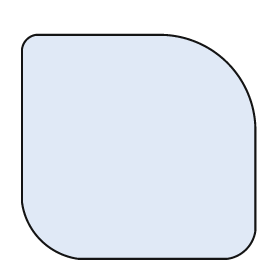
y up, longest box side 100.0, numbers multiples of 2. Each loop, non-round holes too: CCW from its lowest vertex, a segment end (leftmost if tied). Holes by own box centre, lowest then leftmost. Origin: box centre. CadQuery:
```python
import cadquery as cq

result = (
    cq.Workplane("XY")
    .moveTo(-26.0, -48.0)
    .lineTo(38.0, -48.0)
    .threePointArc((46.0, -44.0), (50.0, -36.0))
    .lineTo(50.0, 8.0)
    .threePointArc((38.0, 36.0), (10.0, 48.0))
    .lineTo(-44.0, 48.0)
    .threePointArc((-48.0, 46.0), (-50.0, 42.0))
    .lineTo(-50.0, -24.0)
    .threePointArc((-42.0, -40.0), (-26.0, -48.0))
    .close()
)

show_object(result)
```